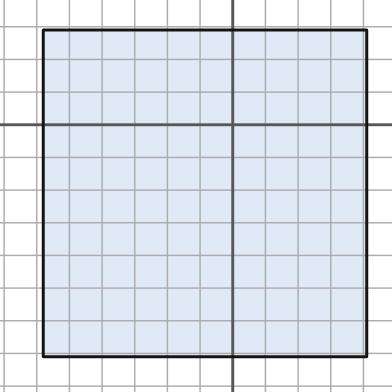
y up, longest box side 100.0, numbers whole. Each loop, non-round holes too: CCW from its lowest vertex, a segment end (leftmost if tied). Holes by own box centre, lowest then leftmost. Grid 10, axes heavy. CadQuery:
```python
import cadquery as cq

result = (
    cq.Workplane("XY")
    .moveTo(-58.0, -71.0)
    .lineTo(41.0, -71.0)
    .lineTo(41.0, 29.0)
    .lineTo(-58.0, 29.0)
    .close()
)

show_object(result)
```